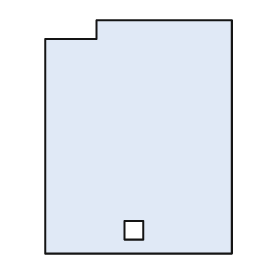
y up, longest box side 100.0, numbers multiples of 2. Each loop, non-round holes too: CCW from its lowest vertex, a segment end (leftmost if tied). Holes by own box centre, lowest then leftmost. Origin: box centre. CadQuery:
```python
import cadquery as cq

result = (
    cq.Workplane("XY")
    .moveTo(-40.0, -50.0)
    .lineTo(40.0, -50.0)
    .lineTo(40.0, 50.0)
    .lineTo(-18.0, 50.0)
    .lineTo(-18.0, 42.0)
    .lineTo(-40.0, 42.0)
    .close()
    .moveTo(-6.0, -44.0)
    .lineTo(2.0, -44.0)
    .lineTo(2.0, -36.0)
    .lineTo(-6.0, -36.0)
    .close()
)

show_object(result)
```